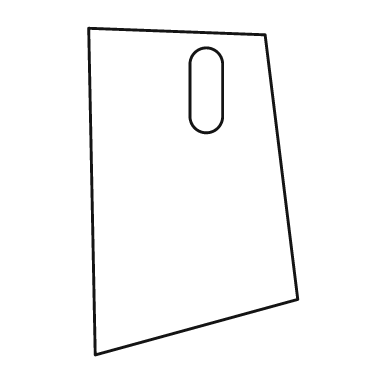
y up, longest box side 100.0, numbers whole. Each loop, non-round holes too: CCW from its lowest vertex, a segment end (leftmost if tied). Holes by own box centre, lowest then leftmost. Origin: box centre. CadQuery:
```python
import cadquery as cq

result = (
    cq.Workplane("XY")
    .moveTo(-30.0, -50.0)
    .lineTo(32.0, -33.0)
    .lineTo(22.0, 48.0)
    .lineTo(-32.0, 50.0)
    .close()
    .moveTo(-1.0, 23.0)
    .threePointArc((4.0, 18.0), (9.0, 23.0))
    .lineTo(9.0, 39.0)
    .threePointArc((4.0, 44.0), (-1.0, 39.0))
    .close()
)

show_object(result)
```